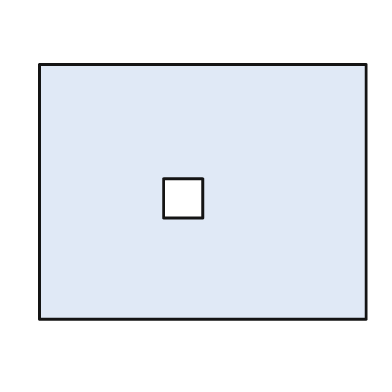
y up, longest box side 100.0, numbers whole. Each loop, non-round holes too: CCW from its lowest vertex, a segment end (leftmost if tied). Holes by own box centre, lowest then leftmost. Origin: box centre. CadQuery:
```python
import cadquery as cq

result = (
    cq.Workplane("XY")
    .moveTo(-50.0, -39.0)
    .lineTo(50.0, -39.0)
    .lineTo(50.0, 39.0)
    .lineTo(-50.0, 39.0)
    .close()
    .moveTo(-12.0, -8.0)
    .lineTo(0.0, -8.0)
    .lineTo(0.0, 4.0)
    .lineTo(-12.0, 4.0)
    .close()
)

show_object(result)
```